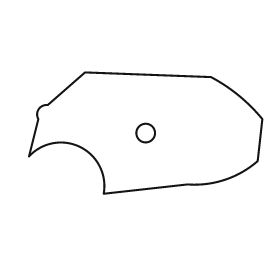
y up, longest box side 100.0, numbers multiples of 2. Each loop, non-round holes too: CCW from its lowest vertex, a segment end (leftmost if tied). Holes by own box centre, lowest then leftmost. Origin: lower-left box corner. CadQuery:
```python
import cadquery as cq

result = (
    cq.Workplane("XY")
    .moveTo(32.0, 0.0)
    .lineTo(68.0, 4.0)
    .threePointArc((84.0, 6.0), (98.0, 14.0))
    .lineTo(100.0, 32.0)
    .threePointArc((90.0, 42.0), (78.0, 50.0))
    .lineTo(24.0, 52.0)
    .lineTo(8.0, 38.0)
    .threePointArc((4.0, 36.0), (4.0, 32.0))
    .lineTo(0.0, 16.0)
    .threePointArc((22.0, 20.0), (32.0, 0.0))
    .close()
    .moveTo(50.0, 26.0)
    .circle(4.0)
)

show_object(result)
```